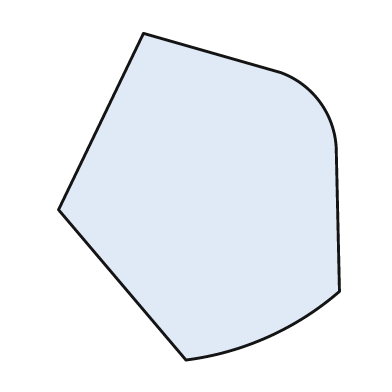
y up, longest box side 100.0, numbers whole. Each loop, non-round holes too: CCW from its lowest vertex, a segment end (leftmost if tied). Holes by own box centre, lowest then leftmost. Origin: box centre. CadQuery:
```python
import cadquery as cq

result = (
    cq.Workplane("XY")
    .moveTo(-4.0, -50.0)
    .threePointArc((21.0, -43.0), (43.0, -29.0))
    .lineTo(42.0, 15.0)
    .threePointArc((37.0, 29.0), (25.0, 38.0))
    .lineTo(-17.0, 50.0)
    .lineTo(-43.0, -4.0)
    .close()
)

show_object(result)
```